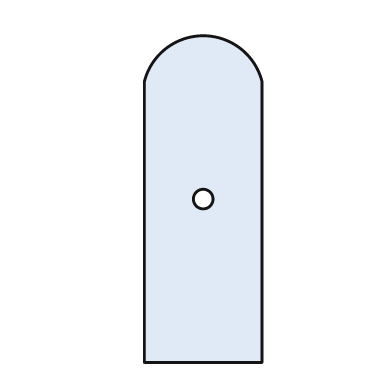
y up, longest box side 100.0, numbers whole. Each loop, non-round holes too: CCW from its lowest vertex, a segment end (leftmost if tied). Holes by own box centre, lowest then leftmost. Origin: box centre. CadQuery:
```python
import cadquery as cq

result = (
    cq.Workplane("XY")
    .moveTo(-18.0, -50.0)
    .lineTo(18.0, -50.0)
    .lineTo(18.0, 36.0)
    .threePointArc((0.0, 50.0), (-18.0, 36.0))
    .close()
    .moveTo(0.0, 0.0)
    .circle(3.0)
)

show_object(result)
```